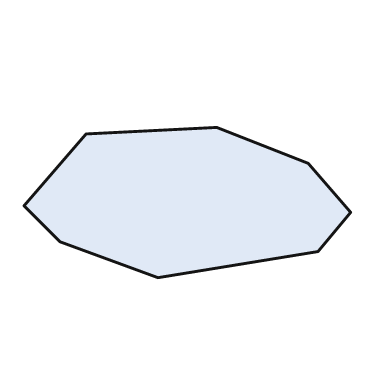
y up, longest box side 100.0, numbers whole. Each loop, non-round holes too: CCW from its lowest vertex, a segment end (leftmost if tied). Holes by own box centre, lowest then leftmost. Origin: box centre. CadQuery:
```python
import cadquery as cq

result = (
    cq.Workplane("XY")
    .moveTo(-9.0, -23.0)
    .lineTo(40.0, -15.0)
    .lineTo(50.0, -3.0)
    .lineTo(37.0, 12.0)
    .lineTo(9.0, 23.0)
    .lineTo(-31.0, 21.0)
    .lineTo(-50.0, -1.0)
    .lineTo(-39.0, -12.0)
    .close()
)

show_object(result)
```